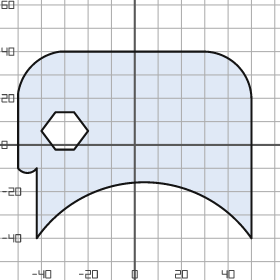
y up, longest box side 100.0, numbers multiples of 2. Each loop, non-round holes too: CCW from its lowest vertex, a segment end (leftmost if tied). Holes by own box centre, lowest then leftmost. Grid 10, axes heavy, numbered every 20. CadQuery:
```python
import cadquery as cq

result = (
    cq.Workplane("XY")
    .moveTo(-42.0, -40.0)
    .threePointArc((4.0, -16.0), (50.0, -40.0))
    .lineTo(50.0, 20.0)
    .threePointArc((44.0, 34.0), (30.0, 40.0))
    .lineTo(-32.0, 40.0)
    .threePointArc((-44.0, 34.0), (-50.0, 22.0))
    .lineTo(-50.0, -10.0)
    .threePointArc((-46.0, -12.0), (-42.0, -10.0))
    .close()
    .moveTo(-34.0, -2.0)
    .lineTo(-26.0, -2.0)
    .lineTo(-20.0, 6.0)
    .lineTo(-26.0, 14.0)
    .lineTo(-34.0, 14.0)
    .lineTo(-40.0, 6.0)
    .close()
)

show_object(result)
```